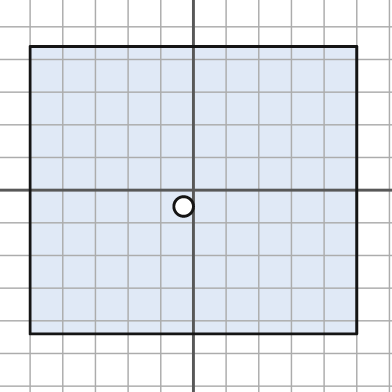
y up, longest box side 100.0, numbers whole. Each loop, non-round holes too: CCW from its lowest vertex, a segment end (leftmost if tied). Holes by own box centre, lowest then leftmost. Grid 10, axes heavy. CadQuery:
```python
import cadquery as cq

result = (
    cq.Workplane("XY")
    .moveTo(-50.0, -44.0)
    .lineTo(50.0, -44.0)
    .lineTo(50.0, 44.0)
    .lineTo(-50.0, 44.0)
    .close()
    .moveTo(-3.0, -5.0)
    .circle(3.0)
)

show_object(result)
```